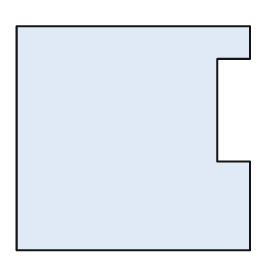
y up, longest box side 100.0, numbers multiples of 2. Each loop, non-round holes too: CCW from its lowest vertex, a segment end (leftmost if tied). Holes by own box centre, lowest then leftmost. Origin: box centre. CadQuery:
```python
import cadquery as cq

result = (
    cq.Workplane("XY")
    .moveTo(-50.0, -48.0)
    .lineTo(50.0, -48.0)
    .lineTo(50.0, -10.0)
    .lineTo(36.0, -10.0)
    .lineTo(36.0, 34.0)
    .lineTo(50.0, 34.0)
    .lineTo(50.0, 48.0)
    .lineTo(-50.0, 48.0)
    .close()
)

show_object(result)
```